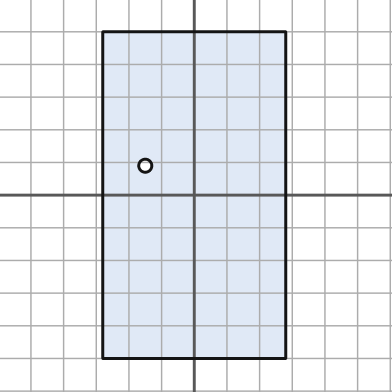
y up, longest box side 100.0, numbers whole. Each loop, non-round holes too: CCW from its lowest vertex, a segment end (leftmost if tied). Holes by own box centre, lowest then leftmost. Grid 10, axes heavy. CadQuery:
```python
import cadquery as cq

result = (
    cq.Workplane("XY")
    .moveTo(-28.0, -50.0)
    .lineTo(28.0, -50.0)
    .lineTo(28.0, 50.0)
    .lineTo(-28.0, 50.0)
    .close()
    .moveTo(-15.0, 9.0)
    .circle(2.0)
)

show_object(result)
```